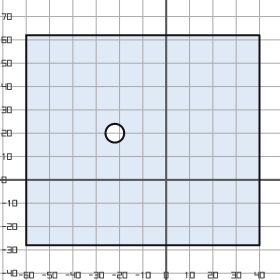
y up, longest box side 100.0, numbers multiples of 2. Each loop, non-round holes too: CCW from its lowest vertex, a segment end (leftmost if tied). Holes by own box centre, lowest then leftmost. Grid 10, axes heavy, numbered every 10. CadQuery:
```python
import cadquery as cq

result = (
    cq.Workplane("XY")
    .moveTo(-60.0, -28.0)
    .lineTo(40.0, -28.0)
    .lineTo(40.0, 62.0)
    .lineTo(-60.0, 62.0)
    .close()
    .moveTo(-22.0, 20.0)
    .circle(4.0)
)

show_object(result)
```